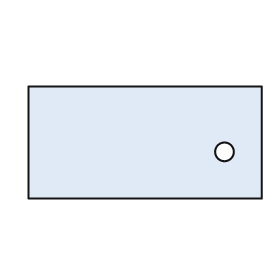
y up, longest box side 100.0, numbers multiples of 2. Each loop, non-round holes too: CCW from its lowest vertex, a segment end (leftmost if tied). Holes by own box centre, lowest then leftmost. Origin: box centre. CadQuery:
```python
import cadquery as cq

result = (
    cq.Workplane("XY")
    .moveTo(-50.0, -24.0)
    .lineTo(50.0, -24.0)
    .lineTo(50.0, 24.0)
    .lineTo(-50.0, 24.0)
    .close()
    .moveTo(34.0, -4.0)
    .circle(4.0)
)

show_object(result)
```